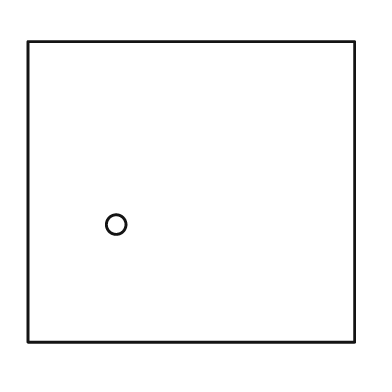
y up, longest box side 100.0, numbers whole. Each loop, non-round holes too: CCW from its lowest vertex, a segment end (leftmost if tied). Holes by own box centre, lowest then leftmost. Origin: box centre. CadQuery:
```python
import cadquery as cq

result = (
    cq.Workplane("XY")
    .moveTo(-50.0, -46.0)
    .lineTo(50.0, -46.0)
    .lineTo(50.0, 46.0)
    .lineTo(-50.0, 46.0)
    .close()
    .moveTo(-23.0, -10.0)
    .circle(3.0)
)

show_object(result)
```